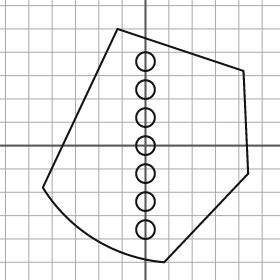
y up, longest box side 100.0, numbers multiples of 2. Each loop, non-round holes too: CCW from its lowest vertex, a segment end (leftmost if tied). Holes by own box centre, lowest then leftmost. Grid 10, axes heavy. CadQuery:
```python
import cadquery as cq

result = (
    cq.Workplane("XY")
    .moveTo(8.0, -50.0)
    .lineTo(44.0, -12.0)
    .lineTo(42.0, 32.0)
    .lineTo(-12.0, 50.0)
    .lineTo(-44.0, -18.0)
    .threePointArc((-22.0, -40.0), (8.0, -50.0))
    .close()
    .moveTo(0.0, -36.0)
    .circle(4.0)
    .moveTo(0.0, -24.0)
    .circle(4.0)
    .moveTo(0.0, -12.0)
    .circle(4.0)
    .moveTo(0.0, 0.0)
    .circle(4.0)
    .moveTo(0.0, 12.0)
    .circle(4.0)
    .moveTo(0.0, 24.0)
    .circle(4.0)
    .moveTo(0.0, 36.0)
    .circle(4.0)
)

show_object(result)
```